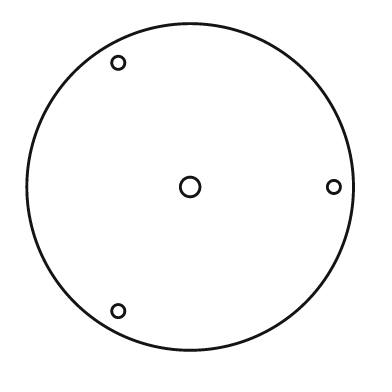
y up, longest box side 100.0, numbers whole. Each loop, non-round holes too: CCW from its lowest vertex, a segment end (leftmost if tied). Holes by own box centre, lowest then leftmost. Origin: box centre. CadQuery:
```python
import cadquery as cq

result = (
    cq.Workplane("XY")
    .moveTo(0.0, 0.0)
    .circle(50.0)
    .moveTo(-22.0, -38.0)
    .circle(2.0)
    .moveTo(0.0, 0.0)
    .circle(3.0)
    .moveTo(44.0, 0.0)
    .circle(2.0)
    .moveTo(-22.0, 38.0)
    .circle(2.0)
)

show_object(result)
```